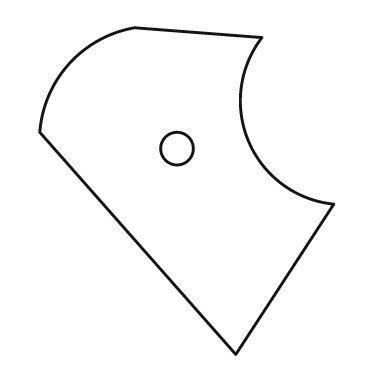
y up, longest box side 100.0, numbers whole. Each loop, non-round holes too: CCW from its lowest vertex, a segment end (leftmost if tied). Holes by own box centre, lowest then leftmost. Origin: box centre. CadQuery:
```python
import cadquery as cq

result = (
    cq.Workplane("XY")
    .moveTo(15.0, -50.0)
    .lineTo(45.0, -4.0)
    .threePointArc((19.0, 15.0), (23.0, 47.0))
    .lineTo(-16.0, 50.0)
    .threePointArc((-36.0, 39.0), (-45.0, 18.0))
    .close()
    .moveTo(-3.0, 13.0)
    .circle(5.0)
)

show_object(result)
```